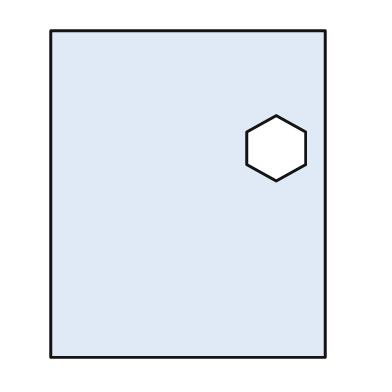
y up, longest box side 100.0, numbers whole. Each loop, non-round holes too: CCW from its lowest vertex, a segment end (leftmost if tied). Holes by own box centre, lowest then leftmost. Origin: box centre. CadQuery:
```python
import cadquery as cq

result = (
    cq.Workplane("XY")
    .moveTo(-42.0, -50.0)
    .lineTo(42.0, -50.0)
    .lineTo(42.0, 50.0)
    .lineTo(-42.0, 50.0)
    .close()
    .moveTo(27.0, 4.0)
    .lineTo(36.0, 9.0)
    .lineTo(36.0, 19.0)
    .lineTo(27.0, 24.0)
    .lineTo(18.0, 19.0)
    .lineTo(18.0, 9.0)
    .close()
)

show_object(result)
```